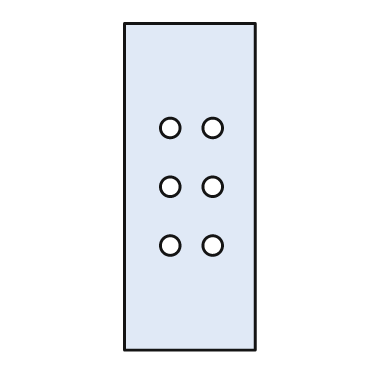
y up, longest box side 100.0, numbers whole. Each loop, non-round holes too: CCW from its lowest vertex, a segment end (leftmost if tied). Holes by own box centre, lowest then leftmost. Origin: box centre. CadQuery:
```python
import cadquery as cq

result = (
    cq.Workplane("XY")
    .moveTo(-20.0, -50.0)
    .lineTo(20.0, -50.0)
    .lineTo(20.0, 50.0)
    .lineTo(-20.0, 50.0)
    .close()
    .moveTo(-6.0, -18.0)
    .circle(3.0)
    .moveTo(7.0, -18.0)
    .circle(3.0)
    .moveTo(-6.0, 0.0)
    .circle(3.0)
    .moveTo(7.0, 0.0)
    .circle(3.0)
    .moveTo(-6.0, 18.0)
    .circle(3.0)
    .moveTo(7.0, 18.0)
    .circle(3.0)
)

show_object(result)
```